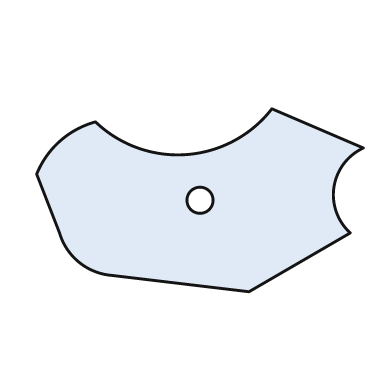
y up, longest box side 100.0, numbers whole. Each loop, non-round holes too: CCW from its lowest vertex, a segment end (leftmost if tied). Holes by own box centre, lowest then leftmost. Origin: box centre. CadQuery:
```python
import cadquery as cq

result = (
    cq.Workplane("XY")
    .moveTo(15.0, -28.0)
    .lineTo(46.0, -10.0)
    .threePointArc((41.0, 4.0), (50.0, 16.0))
    .lineTo(22.0, 28.0)
    .threePointArc((-4.0, 14.0), (-32.0, 24.0))
    .threePointArc((-43.0, 18.0), (-50.0, 8.0))
    .lineTo(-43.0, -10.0)
    .threePointArc((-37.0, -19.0), (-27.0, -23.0))
    .close()
    .moveTo(0.0, 0.0)
    .circle(4.0)
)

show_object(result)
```